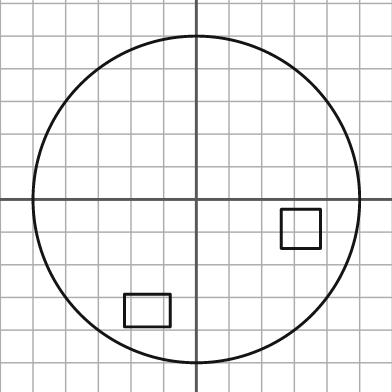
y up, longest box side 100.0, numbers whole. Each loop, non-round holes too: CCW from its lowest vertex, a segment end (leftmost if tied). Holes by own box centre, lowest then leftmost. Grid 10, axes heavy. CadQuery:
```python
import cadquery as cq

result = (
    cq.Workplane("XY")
    .moveTo(0.0, 0.0)
    .circle(50.0)
    .moveTo(-22.0, -39.0)
    .lineTo(-8.0, -39.0)
    .lineTo(-8.0, -29.0)
    .lineTo(-22.0, -29.0)
    .close()
    .moveTo(26.0, -15.0)
    .lineTo(38.0, -15.0)
    .lineTo(38.0, -3.0)
    .lineTo(26.0, -3.0)
    .close()
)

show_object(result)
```